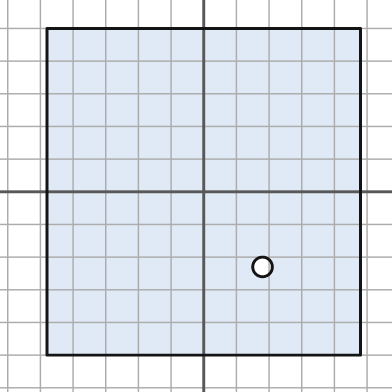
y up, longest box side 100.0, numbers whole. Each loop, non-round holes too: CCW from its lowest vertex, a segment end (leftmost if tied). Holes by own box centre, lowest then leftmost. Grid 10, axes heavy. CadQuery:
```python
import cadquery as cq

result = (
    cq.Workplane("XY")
    .moveTo(-48.0, -50.0)
    .lineTo(48.0, -50.0)
    .lineTo(48.0, 50.0)
    .lineTo(-48.0, 50.0)
    .close()
    .moveTo(18.0, -23.0)
    .circle(3.0)
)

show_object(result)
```